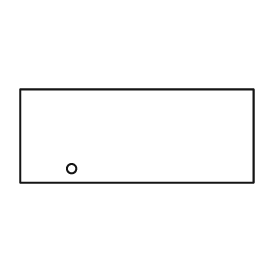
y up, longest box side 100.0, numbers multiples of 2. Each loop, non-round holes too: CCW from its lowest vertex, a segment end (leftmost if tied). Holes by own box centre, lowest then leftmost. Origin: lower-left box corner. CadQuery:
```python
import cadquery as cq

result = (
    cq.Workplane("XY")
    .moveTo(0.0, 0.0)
    .lineTo(100.0, 0.0)
    .lineTo(100.0, 40.0)
    .lineTo(0.0, 40.0)
    .close()
    .moveTo(22.0, 6.0)
    .circle(2.0)
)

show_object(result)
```